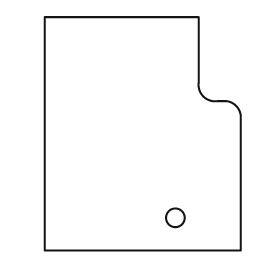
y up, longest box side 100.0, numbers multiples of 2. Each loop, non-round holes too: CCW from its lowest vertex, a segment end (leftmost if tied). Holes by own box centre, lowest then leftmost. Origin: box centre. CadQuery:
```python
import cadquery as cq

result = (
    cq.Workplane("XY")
    .moveTo(-42.0, -50.0)
    .lineTo(42.0, -50.0)
    .lineTo(42.0, 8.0)
    .threePointArc((40.0, 12.0), (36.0, 14.0))
    .lineTo(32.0, 14.0)
    .threePointArc((26.0, 16.0), (24.0, 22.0))
    .lineTo(24.0, 50.0)
    .lineTo(-42.0, 50.0)
    .close()
    .moveTo(14.0, -36.0)
    .circle(4.0)
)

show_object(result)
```